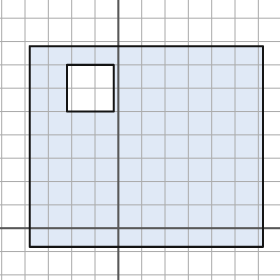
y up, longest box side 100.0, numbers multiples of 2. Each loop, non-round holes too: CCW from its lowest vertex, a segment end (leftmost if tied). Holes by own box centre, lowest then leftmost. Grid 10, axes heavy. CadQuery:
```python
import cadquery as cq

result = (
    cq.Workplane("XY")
    .moveTo(-38.0, -8.0)
    .lineTo(62.0, -8.0)
    .lineTo(62.0, 78.0)
    .lineTo(-38.0, 78.0)
    .close()
    .moveTo(-22.0, 50.0)
    .lineTo(-2.0, 50.0)
    .lineTo(-2.0, 70.0)
    .lineTo(-22.0, 70.0)
    .close()
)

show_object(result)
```